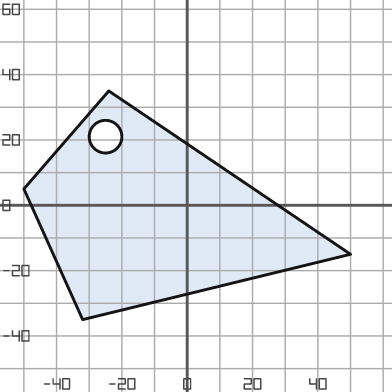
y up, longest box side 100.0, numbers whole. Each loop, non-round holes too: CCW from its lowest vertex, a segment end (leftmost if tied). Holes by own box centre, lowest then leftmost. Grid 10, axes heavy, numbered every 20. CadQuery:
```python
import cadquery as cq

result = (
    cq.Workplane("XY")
    .moveTo(-32.0, -35.0)
    .lineTo(50.0, -15.0)
    .lineTo(-24.0, 35.0)
    .lineTo(-50.0, 5.0)
    .close()
    .moveTo(-25.0, 21.0)
    .circle(5.0)
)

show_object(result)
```